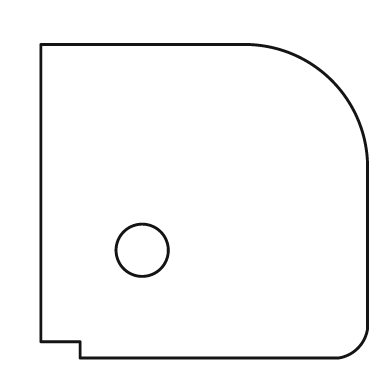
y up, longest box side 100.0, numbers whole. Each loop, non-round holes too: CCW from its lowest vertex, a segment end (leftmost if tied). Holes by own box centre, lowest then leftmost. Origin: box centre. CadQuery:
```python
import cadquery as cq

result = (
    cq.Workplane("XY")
    .moveTo(-38.0, -48.0)
    .lineTo(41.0, -48.0)
    .threePointArc((47.0, -45.0), (50.0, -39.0))
    .lineTo(50.0, 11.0)
    .threePointArc((39.0, 37.0), (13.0, 48.0))
    .lineTo(-50.0, 48.0)
    .lineTo(-50.0, -43.0)
    .lineTo(-38.0, -43.0)
    .close()
    .moveTo(-19.0, -15.0)
    .circle(8.0)
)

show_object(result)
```